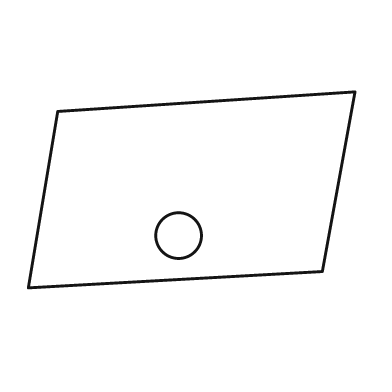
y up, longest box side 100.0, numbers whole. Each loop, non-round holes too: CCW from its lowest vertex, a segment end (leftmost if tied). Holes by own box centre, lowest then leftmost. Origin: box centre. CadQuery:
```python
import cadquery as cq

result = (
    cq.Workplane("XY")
    .moveTo(-50.0, -30.0)
    .lineTo(40.0, -25.0)
    .lineTo(50.0, 30.0)
    .lineTo(-41.0, 24.0)
    .close()
    .moveTo(-4.0, -14.0)
    .circle(7.0)
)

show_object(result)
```